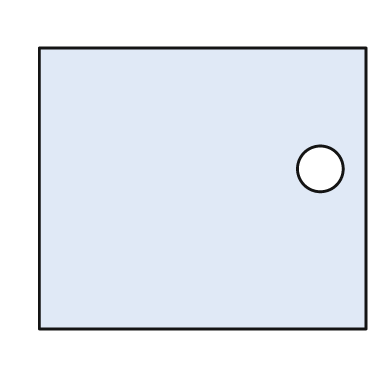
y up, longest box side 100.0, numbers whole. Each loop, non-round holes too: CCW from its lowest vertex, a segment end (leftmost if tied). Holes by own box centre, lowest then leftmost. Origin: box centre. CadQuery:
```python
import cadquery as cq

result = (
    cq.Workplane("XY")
    .moveTo(-50.0, -43.0)
    .lineTo(50.0, -43.0)
    .lineTo(50.0, 43.0)
    .lineTo(-50.0, 43.0)
    .close()
    .moveTo(36.0, 6.0)
    .circle(7.0)
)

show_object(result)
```